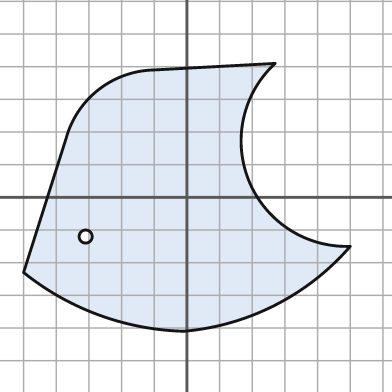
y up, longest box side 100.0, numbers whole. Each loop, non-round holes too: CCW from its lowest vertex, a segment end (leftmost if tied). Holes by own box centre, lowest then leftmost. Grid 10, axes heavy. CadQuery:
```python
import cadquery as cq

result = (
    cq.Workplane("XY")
    .moveTo(-1.0, -41.0)
    .threePointArc((27.0, -33.0), (50.0, -15.0))
    .threePointArc((19.0, 5.0), (27.0, 41.0))
    .lineTo(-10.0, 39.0)
    .threePointArc((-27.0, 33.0), (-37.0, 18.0))
    .lineTo(-50.0, -23.0)
    .threePointArc((-27.0, -36.0), (-1.0, -41.0))
    .close()
    .moveTo(-31.0, -12.0)
    .circle(2.0)
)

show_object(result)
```